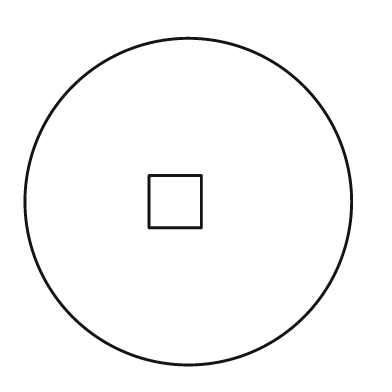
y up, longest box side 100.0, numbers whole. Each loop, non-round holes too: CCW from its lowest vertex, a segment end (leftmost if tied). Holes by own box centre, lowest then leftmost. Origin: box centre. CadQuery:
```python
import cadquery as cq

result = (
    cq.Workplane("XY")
    .moveTo(0.0, 0.0)
    .circle(50.0)
    .moveTo(-12.0, -8.0)
    .lineTo(4.0, -8.0)
    .lineTo(4.0, 8.0)
    .lineTo(-12.0, 8.0)
    .close()
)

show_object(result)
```